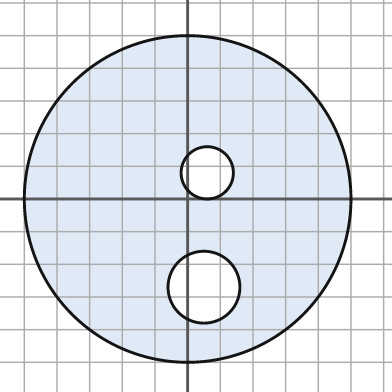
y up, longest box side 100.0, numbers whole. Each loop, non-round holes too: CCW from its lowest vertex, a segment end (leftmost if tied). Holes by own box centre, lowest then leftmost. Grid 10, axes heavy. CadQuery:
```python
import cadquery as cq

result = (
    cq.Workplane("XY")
    .moveTo(0.0, 0.0)
    .circle(50.0)
    .moveTo(5.0, -27.0)
    .circle(11.0)
    .moveTo(6.0, 8.0)
    .circle(8.0)
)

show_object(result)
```